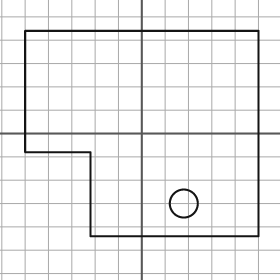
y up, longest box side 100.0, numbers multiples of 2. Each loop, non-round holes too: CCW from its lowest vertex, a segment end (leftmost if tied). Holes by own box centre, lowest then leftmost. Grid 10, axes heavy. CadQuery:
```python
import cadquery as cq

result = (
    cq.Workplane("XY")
    .moveTo(-22.0, -44.0)
    .lineTo(50.0, -44.0)
    .lineTo(50.0, 44.0)
    .lineTo(-50.0, 44.0)
    .lineTo(-50.0, -8.0)
    .lineTo(-22.0, -8.0)
    .close()
    .moveTo(18.0, -30.0)
    .circle(6.0)
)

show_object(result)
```